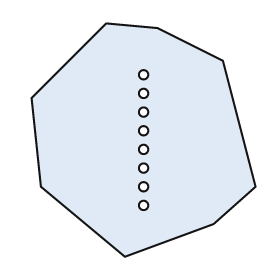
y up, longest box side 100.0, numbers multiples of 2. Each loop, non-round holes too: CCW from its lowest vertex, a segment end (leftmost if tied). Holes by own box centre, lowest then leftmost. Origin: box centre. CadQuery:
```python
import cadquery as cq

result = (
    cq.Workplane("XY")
    .moveTo(-8.0, -50.0)
    .lineTo(30.0, -36.0)
    .lineTo(48.0, -20.0)
    .lineTo(34.0, 34.0)
    .lineTo(6.0, 48.0)
    .lineTo(-16.0, 50.0)
    .lineTo(-48.0, 18.0)
    .lineTo(-44.0, -20.0)
    .close()
    .moveTo(0.0, -28.0)
    .circle(2.0)
    .moveTo(0.0, -20.0)
    .circle(2.0)
    .moveTo(0.0, -12.0)
    .circle(2.0)
    .moveTo(0.0, -4.0)
    .circle(2.0)
    .moveTo(0.0, 4.0)
    .circle(2.0)
    .moveTo(0.0, 12.0)
    .circle(2.0)
    .moveTo(0.0, 20.0)
    .circle(2.0)
    .moveTo(0.0, 28.0)
    .circle(2.0)
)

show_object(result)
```